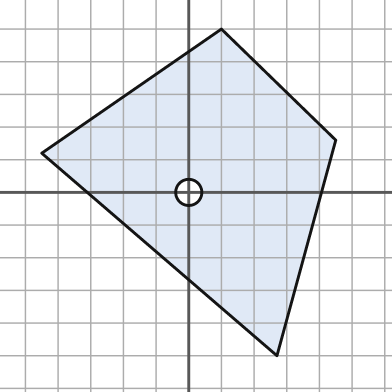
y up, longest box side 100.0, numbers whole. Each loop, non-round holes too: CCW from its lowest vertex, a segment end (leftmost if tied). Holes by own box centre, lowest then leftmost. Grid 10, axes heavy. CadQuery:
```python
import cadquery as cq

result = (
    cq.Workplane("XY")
    .moveTo(27.0, -50.0)
    .lineTo(45.0, 16.0)
    .lineTo(10.0, 50.0)
    .lineTo(-45.0, 12.0)
    .close()
    .moveTo(0.0, 0.0)
    .circle(4.0)
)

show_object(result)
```